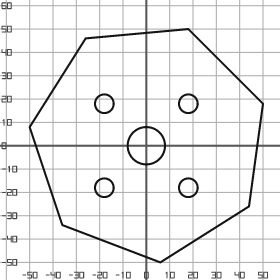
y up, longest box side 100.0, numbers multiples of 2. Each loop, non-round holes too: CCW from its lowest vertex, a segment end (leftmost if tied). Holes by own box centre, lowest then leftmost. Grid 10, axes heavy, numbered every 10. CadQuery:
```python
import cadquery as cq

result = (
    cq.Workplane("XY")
    .moveTo(6.0, -50.0)
    .lineTo(44.0, -26.0)
    .lineTo(50.0, 18.0)
    .lineTo(18.0, 50.0)
    .lineTo(-26.0, 46.0)
    .lineTo(-50.0, 8.0)
    .lineTo(-36.0, -34.0)
    .close()
    .moveTo(-18.0, -18.0)
    .circle(4.0)
    .moveTo(18.0, -18.0)
    .circle(4.0)
    .moveTo(0.0, 0.0)
    .circle(8.0)
    .moveTo(-18.0, 18.0)
    .circle(4.0)
    .moveTo(18.0, 18.0)
    .circle(4.0)
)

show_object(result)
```